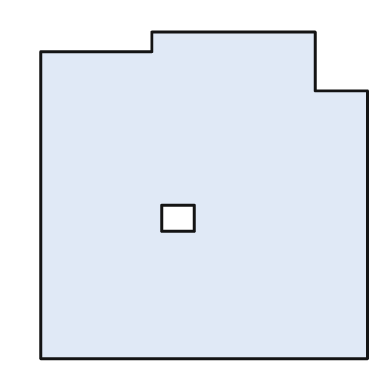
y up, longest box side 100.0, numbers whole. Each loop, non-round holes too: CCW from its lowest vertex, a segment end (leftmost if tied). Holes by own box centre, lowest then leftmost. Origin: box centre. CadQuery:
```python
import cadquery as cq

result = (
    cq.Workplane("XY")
    .moveTo(-50.0, -50.0)
    .lineTo(50.0, -50.0)
    .lineTo(50.0, 32.0)
    .lineTo(34.0, 32.0)
    .lineTo(34.0, 50.0)
    .lineTo(-16.0, 50.0)
    .lineTo(-16.0, 44.0)
    .lineTo(-50.0, 44.0)
    .close()
    .moveTo(-13.0, -11.0)
    .lineTo(-3.0, -11.0)
    .lineTo(-3.0, -3.0)
    .lineTo(-13.0, -3.0)
    .close()
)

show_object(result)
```